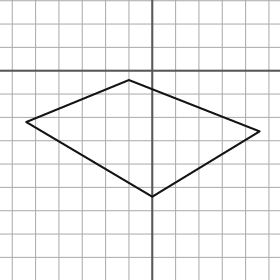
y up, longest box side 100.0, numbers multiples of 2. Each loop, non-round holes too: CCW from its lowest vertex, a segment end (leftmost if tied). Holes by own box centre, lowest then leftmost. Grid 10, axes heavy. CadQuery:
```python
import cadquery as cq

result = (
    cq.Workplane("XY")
    .moveTo(0.0, -54.0)
    .lineTo(46.0, -26.0)
    .lineTo(-10.0, -4.0)
    .lineTo(-54.0, -22.0)
    .close()
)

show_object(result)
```